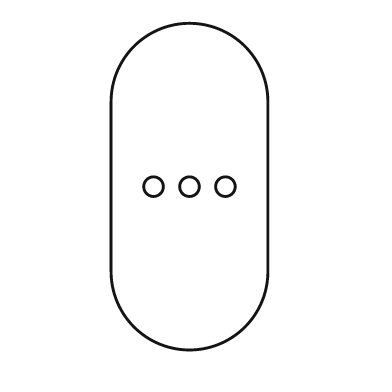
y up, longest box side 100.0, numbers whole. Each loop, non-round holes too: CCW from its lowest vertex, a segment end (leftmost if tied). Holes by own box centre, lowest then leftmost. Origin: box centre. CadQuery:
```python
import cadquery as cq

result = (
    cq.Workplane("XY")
    .moveTo(-24.0, -26.0)
    .threePointArc((0.0, -50.0), (24.0, -26.0))
    .lineTo(24.0, 26.0)
    .threePointArc((0.0, 50.0), (-24.0, 26.0))
    .close()
    .moveTo(-11.0, 0.0)
    .circle(3.0)
    .moveTo(0.0, 0.0)
    .circle(3.0)
    .moveTo(11.0, 0.0)
    .circle(3.0)
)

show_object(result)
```